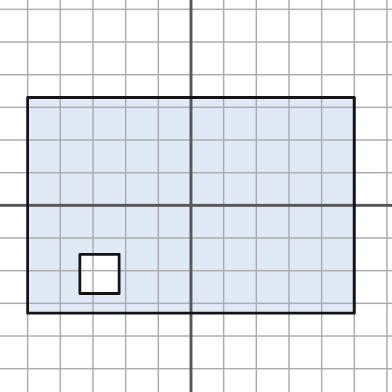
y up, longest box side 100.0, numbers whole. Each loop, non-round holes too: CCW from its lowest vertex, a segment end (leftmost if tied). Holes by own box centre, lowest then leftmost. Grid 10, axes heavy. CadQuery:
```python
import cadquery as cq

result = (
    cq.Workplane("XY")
    .moveTo(-50.0, -33.0)
    .lineTo(50.0, -33.0)
    .lineTo(50.0, 33.0)
    .lineTo(-50.0, 33.0)
    .close()
    .moveTo(-34.0, -27.0)
    .lineTo(-22.0, -27.0)
    .lineTo(-22.0, -15.0)
    .lineTo(-34.0, -15.0)
    .close()
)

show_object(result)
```